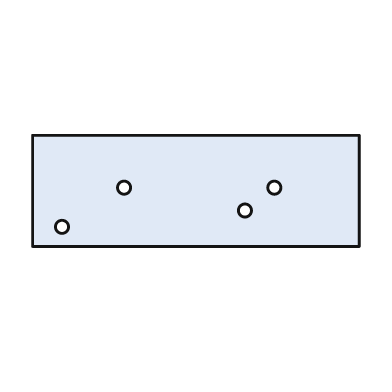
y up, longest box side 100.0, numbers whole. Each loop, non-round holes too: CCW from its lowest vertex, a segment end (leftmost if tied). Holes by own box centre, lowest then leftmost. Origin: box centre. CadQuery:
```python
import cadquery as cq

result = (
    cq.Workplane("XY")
    .moveTo(-50.0, -17.0)
    .lineTo(50.0, -17.0)
    .lineTo(50.0, 17.0)
    .lineTo(-50.0, 17.0)
    .close()
    .moveTo(-41.0, -11.0)
    .circle(2.0)
    .moveTo(15.0, -6.0)
    .circle(2.0)
    .moveTo(-22.0, 1.0)
    .circle(2.0)
    .moveTo(24.0, 1.0)
    .circle(2.0)
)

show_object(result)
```